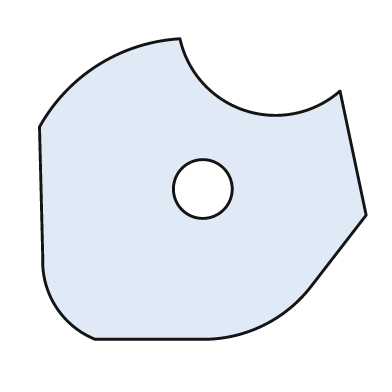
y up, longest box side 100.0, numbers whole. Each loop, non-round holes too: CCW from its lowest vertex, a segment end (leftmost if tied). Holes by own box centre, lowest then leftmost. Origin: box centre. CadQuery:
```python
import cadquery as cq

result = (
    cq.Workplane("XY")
    .moveTo(-33.0, -46.0)
    .lineTo(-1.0, -46.0)
    .threePointArc((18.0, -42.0), (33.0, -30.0))
    .lineTo(50.0, -8.0)
    .lineTo(42.0, 30.0)
    .threePointArc((13.0, 24.0), (-7.0, 46.0))
    .threePointArc((-32.0, 38.0), (-50.0, 19.0))
    .lineTo(-49.0, -21.0)
    .threePointArc((-45.0, -36.0), (-33.0, -46.0))
    .close()
    .moveTo(0.0, 0.0)
    .circle(9.0)
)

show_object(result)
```